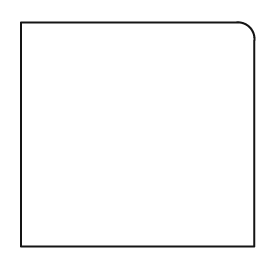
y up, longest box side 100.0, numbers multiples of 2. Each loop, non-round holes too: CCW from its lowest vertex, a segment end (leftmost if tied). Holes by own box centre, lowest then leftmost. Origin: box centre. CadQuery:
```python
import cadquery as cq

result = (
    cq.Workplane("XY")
    .moveTo(-50.0, -48.0)
    .lineTo(50.0, -48.0)
    .lineTo(50.0, 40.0)
    .threePointArc((48.0, 46.0), (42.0, 48.0))
    .lineTo(-50.0, 48.0)
    .close()
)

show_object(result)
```